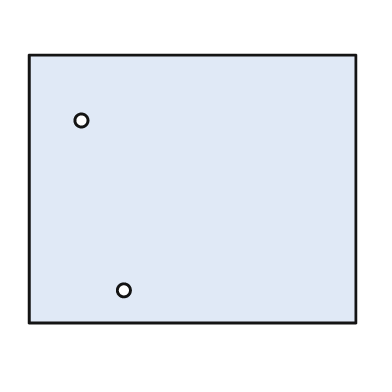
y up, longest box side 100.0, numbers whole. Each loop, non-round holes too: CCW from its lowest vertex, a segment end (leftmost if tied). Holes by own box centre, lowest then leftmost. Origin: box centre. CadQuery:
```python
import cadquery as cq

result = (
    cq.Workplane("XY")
    .moveTo(-50.0, -41.0)
    .lineTo(50.0, -41.0)
    .lineTo(50.0, 41.0)
    .lineTo(-50.0, 41.0)
    .close()
    .moveTo(-21.0, -31.0)
    .circle(2.0)
    .moveTo(-34.0, 21.0)
    .circle(2.0)
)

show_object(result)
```